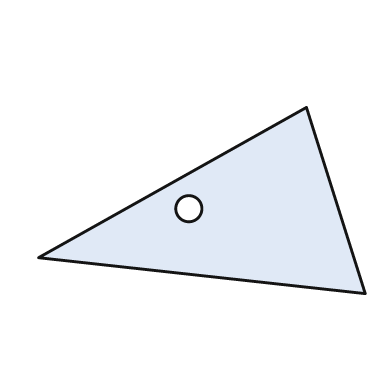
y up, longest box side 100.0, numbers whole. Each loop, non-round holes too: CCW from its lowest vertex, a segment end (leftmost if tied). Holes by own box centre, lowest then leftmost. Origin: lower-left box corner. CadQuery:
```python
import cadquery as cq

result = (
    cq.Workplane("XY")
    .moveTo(100.0, 0.0)
    .lineTo(82.0, 57.0)
    .lineTo(0.0, 11.0)
    .close()
    .moveTo(46.0, 26.0)
    .circle(4.0)
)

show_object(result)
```